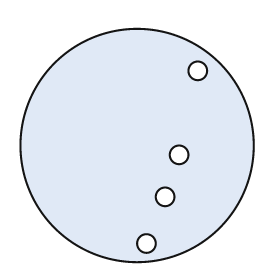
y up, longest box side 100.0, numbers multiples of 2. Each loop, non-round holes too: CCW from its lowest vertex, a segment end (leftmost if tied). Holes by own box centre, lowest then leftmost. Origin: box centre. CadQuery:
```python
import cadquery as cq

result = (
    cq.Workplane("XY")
    .moveTo(0.0, 0.0)
    .circle(50.0)
    .moveTo(4.0, -42.0)
    .circle(4.0)
    .moveTo(12.0, -22.0)
    .circle(4.0)
    .moveTo(18.0, -4.0)
    .circle(4.0)
    .moveTo(26.0, 32.0)
    .circle(4.0)
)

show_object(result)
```